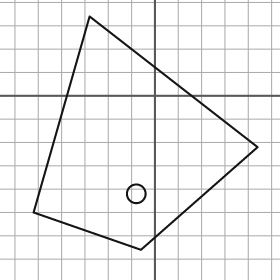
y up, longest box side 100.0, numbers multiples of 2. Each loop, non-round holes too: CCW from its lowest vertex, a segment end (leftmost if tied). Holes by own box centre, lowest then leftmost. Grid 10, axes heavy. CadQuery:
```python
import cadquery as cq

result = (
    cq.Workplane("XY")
    .moveTo(-6.0, -66.0)
    .lineTo(44.0, -22.0)
    .lineTo(-28.0, 34.0)
    .lineTo(-52.0, -50.0)
    .close()
    .moveTo(-8.0, -42.0)
    .circle(4.0)
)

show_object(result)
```